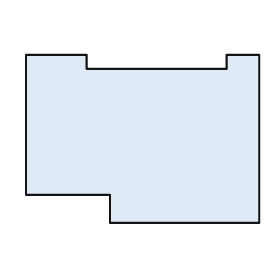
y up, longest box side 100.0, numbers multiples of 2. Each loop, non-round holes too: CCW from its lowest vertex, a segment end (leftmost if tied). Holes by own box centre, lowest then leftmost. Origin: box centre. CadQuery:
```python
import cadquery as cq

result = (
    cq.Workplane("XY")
    .moveTo(-14.0, -36.0)
    .lineTo(50.0, -36.0)
    .lineTo(50.0, 36.0)
    .lineTo(36.0, 36.0)
    .lineTo(36.0, 30.0)
    .lineTo(-24.0, 30.0)
    .lineTo(-24.0, 36.0)
    .lineTo(-50.0, 36.0)
    .lineTo(-50.0, -24.0)
    .lineTo(-14.0, -24.0)
    .close()
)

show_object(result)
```